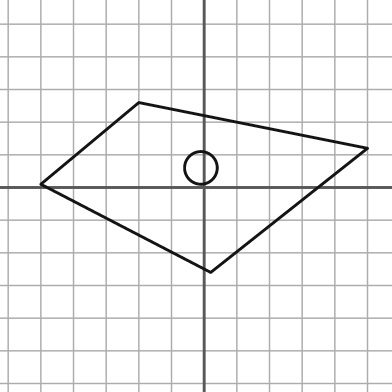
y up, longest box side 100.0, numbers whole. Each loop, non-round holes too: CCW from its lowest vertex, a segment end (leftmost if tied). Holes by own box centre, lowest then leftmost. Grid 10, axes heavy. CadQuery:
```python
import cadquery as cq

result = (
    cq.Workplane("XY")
    .moveTo(2.0, -26.0)
    .lineTo(50.0, 12.0)
    .lineTo(-20.0, 26.0)
    .lineTo(-50.0, 1.0)
    .close()
    .moveTo(-1.0, 6.0)
    .circle(5.0)
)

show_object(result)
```